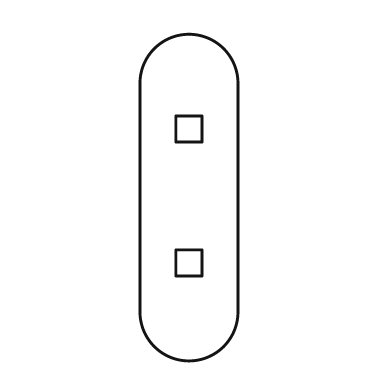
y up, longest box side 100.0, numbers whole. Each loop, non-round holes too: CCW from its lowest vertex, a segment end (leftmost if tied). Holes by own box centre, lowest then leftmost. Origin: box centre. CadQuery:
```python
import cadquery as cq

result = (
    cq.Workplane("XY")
    .moveTo(-15.0, -35.0)
    .threePointArc((0.0, -50.0), (15.0, -35.0))
    .lineTo(15.0, 35.0)
    .threePointArc((0.0, 50.0), (-15.0, 35.0))
    .close()
    .moveTo(-4.0, -24.0)
    .lineTo(4.0, -24.0)
    .lineTo(4.0, -16.0)
    .lineTo(-4.0, -16.0)
    .close()
    .moveTo(-4.0, 17.0)
    .lineTo(4.0, 17.0)
    .lineTo(4.0, 25.0)
    .lineTo(-4.0, 25.0)
    .close()
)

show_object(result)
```